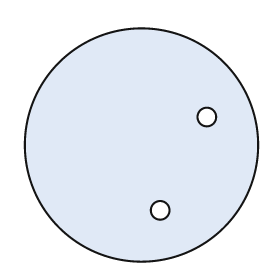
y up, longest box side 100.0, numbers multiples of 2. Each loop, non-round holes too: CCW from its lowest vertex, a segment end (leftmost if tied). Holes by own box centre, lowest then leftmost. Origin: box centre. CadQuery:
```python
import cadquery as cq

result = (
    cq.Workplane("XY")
    .moveTo(0.0, 0.0)
    .circle(50.0)
    .moveTo(8.0, -28.0)
    .circle(4.0)
    .moveTo(28.0, 12.0)
    .circle(4.0)
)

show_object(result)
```